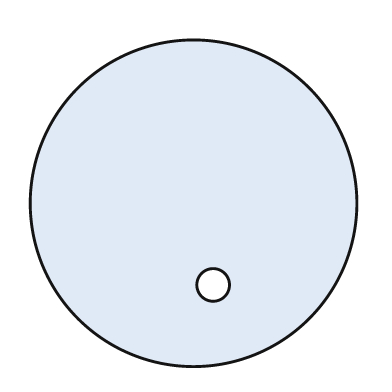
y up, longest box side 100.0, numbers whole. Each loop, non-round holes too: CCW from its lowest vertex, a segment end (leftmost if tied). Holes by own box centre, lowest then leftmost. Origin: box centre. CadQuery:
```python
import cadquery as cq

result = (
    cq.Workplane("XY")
    .moveTo(0.0, 0.0)
    .circle(50.0)
    .moveTo(6.0, -25.0)
    .circle(5.0)
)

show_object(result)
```